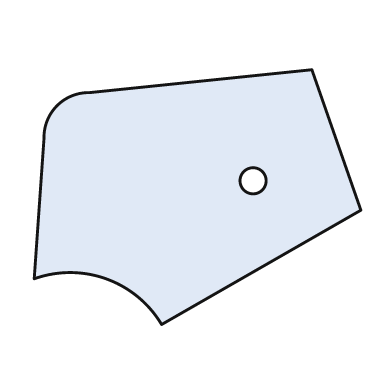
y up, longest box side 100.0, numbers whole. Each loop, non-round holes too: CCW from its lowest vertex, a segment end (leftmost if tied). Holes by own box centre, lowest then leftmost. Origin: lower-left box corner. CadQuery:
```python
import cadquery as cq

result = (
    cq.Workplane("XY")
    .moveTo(39.0, 0.0)
    .lineTo(100.0, 35.0)
    .lineTo(85.0, 78.0)
    .lineTo(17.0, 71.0)
    .threePointArc((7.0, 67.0), (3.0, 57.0))
    .lineTo(0.0, 14.0)
    .threePointArc((22.0, 14.0), (39.0, 0.0))
    .close()
    .moveTo(67.0, 44.0)
    .circle(4.0)
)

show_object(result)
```